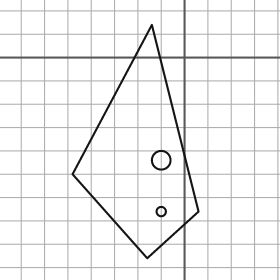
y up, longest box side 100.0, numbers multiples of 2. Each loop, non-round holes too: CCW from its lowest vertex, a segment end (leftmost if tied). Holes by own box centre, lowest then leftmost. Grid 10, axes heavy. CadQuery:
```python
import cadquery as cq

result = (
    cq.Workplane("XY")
    .moveTo(-16.0, -86.0)
    .lineTo(6.0, -66.0)
    .lineTo(-14.0, 14.0)
    .lineTo(-48.0, -50.0)
    .close()
    .moveTo(-10.0, -66.0)
    .circle(2.0)
    .moveTo(-10.0, -44.0)
    .circle(4.0)
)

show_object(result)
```